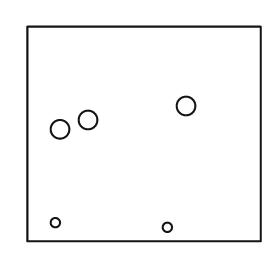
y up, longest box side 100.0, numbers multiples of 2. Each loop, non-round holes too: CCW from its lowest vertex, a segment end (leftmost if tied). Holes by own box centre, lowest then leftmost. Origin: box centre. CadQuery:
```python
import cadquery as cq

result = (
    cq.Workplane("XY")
    .moveTo(-50.0, -46.0)
    .lineTo(50.0, -46.0)
    .lineTo(50.0, 46.0)
    .lineTo(-50.0, 46.0)
    .close()
    .moveTo(10.0, -40.0)
    .circle(2.0)
    .moveTo(-38.0, -38.0)
    .circle(2.0)
    .moveTo(-36.0, 2.0)
    .circle(4.0)
    .moveTo(-24.0, 6.0)
    .circle(4.0)
    .moveTo(18.0, 12.0)
    .circle(4.0)
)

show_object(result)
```